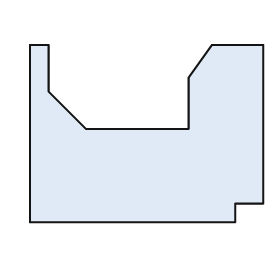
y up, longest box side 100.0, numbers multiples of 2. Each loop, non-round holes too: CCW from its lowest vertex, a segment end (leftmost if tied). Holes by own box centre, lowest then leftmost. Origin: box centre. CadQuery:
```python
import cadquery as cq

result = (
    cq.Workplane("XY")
    .moveTo(-50.0, -38.0)
    .lineTo(38.0, -38.0)
    .lineTo(38.0, -30.0)
    .lineTo(50.0, -30.0)
    .lineTo(50.0, 38.0)
    .lineTo(28.0, 38.0)
    .lineTo(18.0, 24.0)
    .lineTo(18.0, 2.0)
    .lineTo(-26.0, 2.0)
    .lineTo(-42.0, 18.0)
    .lineTo(-42.0, 38.0)
    .lineTo(-50.0, 38.0)
    .close()
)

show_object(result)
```